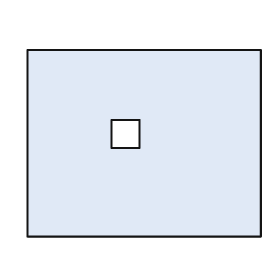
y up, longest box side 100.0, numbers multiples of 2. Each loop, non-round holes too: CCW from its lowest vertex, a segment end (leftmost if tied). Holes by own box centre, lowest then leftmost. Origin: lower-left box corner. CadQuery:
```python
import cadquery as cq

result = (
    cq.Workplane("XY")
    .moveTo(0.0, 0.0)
    .lineTo(100.0, 0.0)
    .lineTo(100.0, 80.0)
    .lineTo(0.0, 80.0)
    .close()
    .moveTo(36.0, 38.0)
    .lineTo(48.0, 38.0)
    .lineTo(48.0, 50.0)
    .lineTo(36.0, 50.0)
    .close()
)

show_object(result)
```